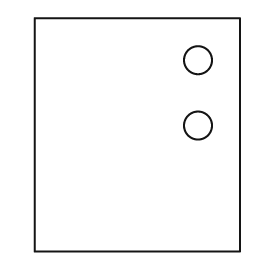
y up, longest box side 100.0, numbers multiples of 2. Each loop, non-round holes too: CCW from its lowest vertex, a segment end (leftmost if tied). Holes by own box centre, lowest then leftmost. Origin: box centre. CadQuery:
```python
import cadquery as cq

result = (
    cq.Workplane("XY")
    .moveTo(-44.0, -50.0)
    .lineTo(44.0, -50.0)
    .lineTo(44.0, 50.0)
    .lineTo(-44.0, 50.0)
    .close()
    .moveTo(26.0, 4.0)
    .circle(6.0)
    .moveTo(26.0, 32.0)
    .circle(6.0)
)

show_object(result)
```